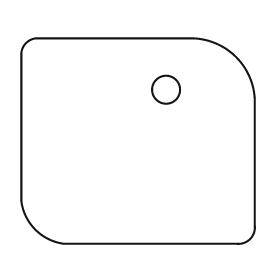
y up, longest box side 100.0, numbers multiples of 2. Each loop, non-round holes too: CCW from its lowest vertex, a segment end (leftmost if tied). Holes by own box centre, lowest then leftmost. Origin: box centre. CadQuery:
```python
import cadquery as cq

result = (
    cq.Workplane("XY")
    .moveTo(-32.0, -44.0)
    .lineTo(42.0, -44.0)
    .threePointArc((48.0, -42.0), (50.0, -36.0))
    .lineTo(50.0, 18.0)
    .threePointArc((42.0, 36.0), (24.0, 44.0))
    .lineTo(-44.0, 44.0)
    .threePointArc((-48.0, 42.0), (-50.0, 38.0))
    .lineTo(-50.0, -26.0)
    .threePointArc((-44.0, -38.0), (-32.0, -44.0))
    .close()
    .moveTo(12.0, 22.0)
    .circle(6.0)
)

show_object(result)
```